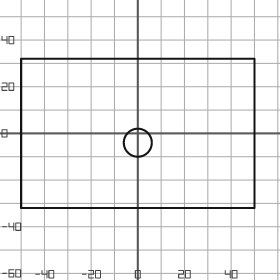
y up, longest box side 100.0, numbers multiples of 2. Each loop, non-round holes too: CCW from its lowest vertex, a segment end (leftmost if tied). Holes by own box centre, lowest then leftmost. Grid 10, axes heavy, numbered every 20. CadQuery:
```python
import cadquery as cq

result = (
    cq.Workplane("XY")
    .moveTo(-50.0, -32.0)
    .lineTo(50.0, -32.0)
    .lineTo(50.0, 32.0)
    .lineTo(-50.0, 32.0)
    .close()
    .moveTo(0.0, -4.0)
    .circle(6.0)
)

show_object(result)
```